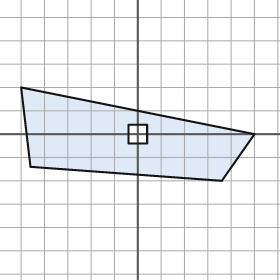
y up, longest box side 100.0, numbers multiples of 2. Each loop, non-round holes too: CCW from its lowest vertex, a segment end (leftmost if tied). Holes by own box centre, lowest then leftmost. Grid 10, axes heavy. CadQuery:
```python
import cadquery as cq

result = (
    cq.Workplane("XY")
    .moveTo(36.0, -20.0)
    .lineTo(50.0, 0.0)
    .lineTo(-50.0, 20.0)
    .lineTo(-46.0, -14.0)
    .close()
    .moveTo(-4.0, -4.0)
    .lineTo(4.0, -4.0)
    .lineTo(4.0, 4.0)
    .lineTo(-4.0, 4.0)
    .close()
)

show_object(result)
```